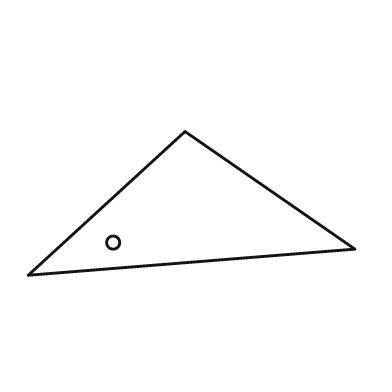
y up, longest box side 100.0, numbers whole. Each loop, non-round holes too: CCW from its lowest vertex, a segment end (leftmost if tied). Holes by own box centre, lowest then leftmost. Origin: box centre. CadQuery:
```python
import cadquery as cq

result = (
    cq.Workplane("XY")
    .moveTo(-50.0, -22.0)
    .lineTo(50.0, -14.0)
    .lineTo(-2.0, 22.0)
    .close()
    .moveTo(-24.0, -12.0)
    .circle(2.0)
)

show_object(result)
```